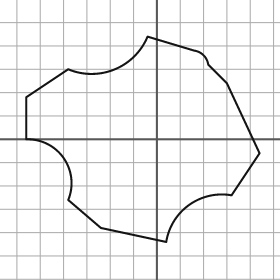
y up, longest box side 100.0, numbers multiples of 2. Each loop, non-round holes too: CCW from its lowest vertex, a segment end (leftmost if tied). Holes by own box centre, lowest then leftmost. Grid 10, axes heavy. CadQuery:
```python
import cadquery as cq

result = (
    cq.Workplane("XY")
    .moveTo(4.0, -44.0)
    .threePointArc((14.0, -28.0), (32.0, -24.0))
    .lineTo(44.0, -6.0)
    .lineTo(30.0, 24.0)
    .lineTo(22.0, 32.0)
    .threePointArc((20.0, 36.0), (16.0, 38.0))
    .lineTo(-4.0, 44.0)
    .threePointArc((-18.0, 30.0), (-38.0, 30.0))
    .lineTo(-56.0, 18.0)
    .lineTo(-56.0, 0.0)
    .threePointArc((-40.0, -8.0), (-38.0, -26.0))
    .lineTo(-24.0, -38.0)
    .close()
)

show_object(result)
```